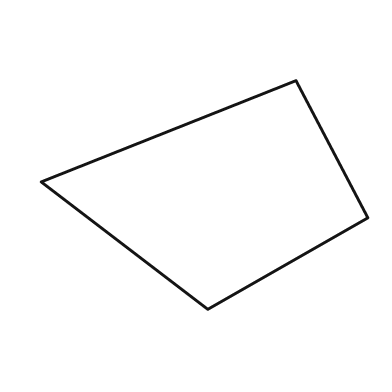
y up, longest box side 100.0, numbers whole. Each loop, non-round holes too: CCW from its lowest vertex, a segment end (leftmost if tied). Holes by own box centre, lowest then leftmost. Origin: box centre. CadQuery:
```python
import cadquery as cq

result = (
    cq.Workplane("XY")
    .moveTo(1.0, -35.0)
    .lineTo(50.0, -7.0)
    .lineTo(28.0, 35.0)
    .lineTo(-50.0, 4.0)
    .close()
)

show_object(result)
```